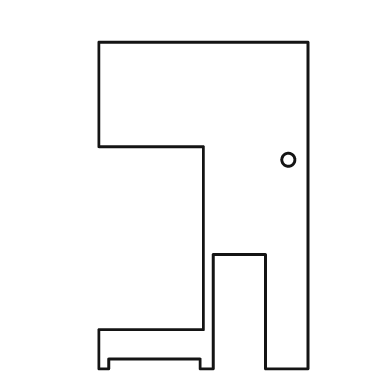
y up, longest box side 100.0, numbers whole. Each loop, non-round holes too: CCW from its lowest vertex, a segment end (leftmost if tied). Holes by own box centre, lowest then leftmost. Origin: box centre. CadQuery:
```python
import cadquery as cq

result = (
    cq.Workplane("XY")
    .moveTo(-32.0, -50.0)
    .lineTo(-29.0, -50.0)
    .lineTo(-29.0, -47.0)
    .lineTo(-1.0, -47.0)
    .lineTo(-1.0, -50.0)
    .lineTo(3.0, -50.0)
    .lineTo(3.0, -15.0)
    .lineTo(19.0, -15.0)
    .lineTo(19.0, -50.0)
    .lineTo(32.0, -50.0)
    .lineTo(32.0, 50.0)
    .lineTo(-32.0, 50.0)
    .lineTo(-32.0, 18.0)
    .lineTo(0.0, 18.0)
    .lineTo(0.0, -38.0)
    .lineTo(-32.0, -38.0)
    .close()
    .moveTo(26.0, 14.0)
    .circle(2.0)
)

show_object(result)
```